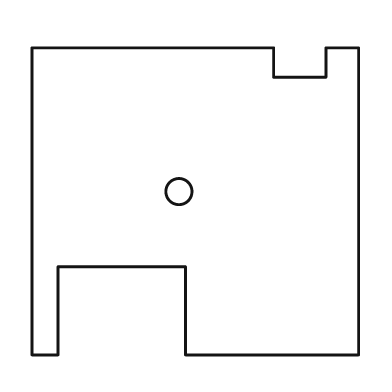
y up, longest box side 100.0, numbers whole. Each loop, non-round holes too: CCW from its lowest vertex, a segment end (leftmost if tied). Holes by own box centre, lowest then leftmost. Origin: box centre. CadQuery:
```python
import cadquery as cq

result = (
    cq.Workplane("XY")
    .moveTo(-50.0, -47.0)
    .lineTo(-42.0, -47.0)
    .lineTo(-42.0, -20.0)
    .lineTo(-3.0, -20.0)
    .lineTo(-3.0, -47.0)
    .lineTo(50.0, -47.0)
    .lineTo(50.0, 47.0)
    .lineTo(40.0, 47.0)
    .lineTo(40.0, 38.0)
    .lineTo(24.0, 38.0)
    .lineTo(24.0, 47.0)
    .lineTo(-50.0, 47.0)
    .close()
    .moveTo(-5.0, 3.0)
    .circle(4.0)
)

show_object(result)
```